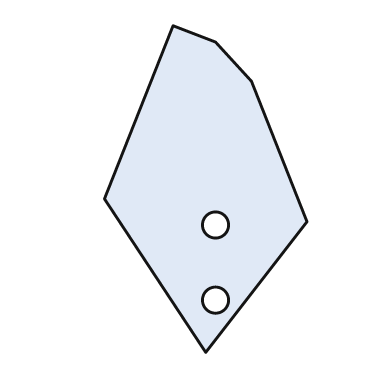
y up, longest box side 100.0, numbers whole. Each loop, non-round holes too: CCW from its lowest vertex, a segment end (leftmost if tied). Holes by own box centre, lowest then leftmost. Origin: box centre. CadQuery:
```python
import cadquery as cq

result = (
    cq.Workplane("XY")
    .moveTo(0.0, -50.0)
    .lineTo(31.0, -10.0)
    .lineTo(14.0, 33.0)
    .lineTo(3.0, 45.0)
    .lineTo(-10.0, 50.0)
    .lineTo(-31.0, -3.0)
    .close()
    .moveTo(3.0, -34.0)
    .circle(4.0)
    .moveTo(3.0, -11.0)
    .circle(4.0)
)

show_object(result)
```